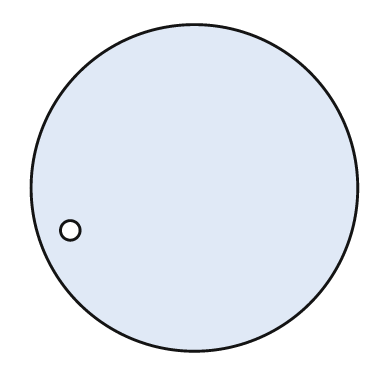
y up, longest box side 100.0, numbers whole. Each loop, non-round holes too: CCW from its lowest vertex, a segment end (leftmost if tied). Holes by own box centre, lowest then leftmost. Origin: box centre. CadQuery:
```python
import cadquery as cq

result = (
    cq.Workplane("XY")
    .moveTo(0.0, 0.0)
    .circle(50.0)
    .moveTo(-38.0, -13.0)
    .circle(3.0)
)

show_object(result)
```